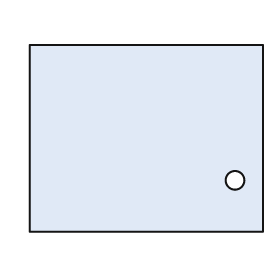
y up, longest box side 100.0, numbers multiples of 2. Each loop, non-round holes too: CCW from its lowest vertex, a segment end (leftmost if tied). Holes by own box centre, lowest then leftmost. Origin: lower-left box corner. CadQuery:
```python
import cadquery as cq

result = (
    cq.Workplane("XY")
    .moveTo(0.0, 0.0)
    .lineTo(100.0, 0.0)
    .lineTo(100.0, 80.0)
    .lineTo(0.0, 80.0)
    .close()
    .moveTo(88.0, 22.0)
    .circle(4.0)
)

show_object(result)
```